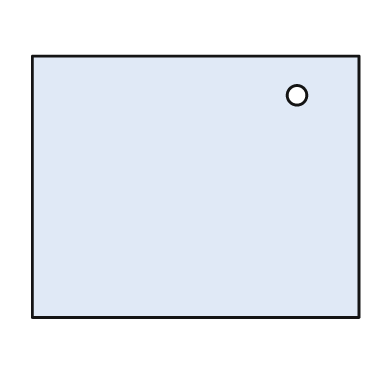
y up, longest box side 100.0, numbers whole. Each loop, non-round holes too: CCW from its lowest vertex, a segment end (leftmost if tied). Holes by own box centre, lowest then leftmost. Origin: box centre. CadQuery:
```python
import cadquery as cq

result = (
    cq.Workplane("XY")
    .moveTo(-50.0, -40.0)
    .lineTo(50.0, -40.0)
    .lineTo(50.0, 40.0)
    .lineTo(-50.0, 40.0)
    .close()
    .moveTo(31.0, 28.0)
    .circle(3.0)
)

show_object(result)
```